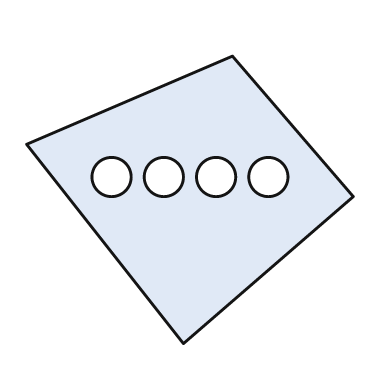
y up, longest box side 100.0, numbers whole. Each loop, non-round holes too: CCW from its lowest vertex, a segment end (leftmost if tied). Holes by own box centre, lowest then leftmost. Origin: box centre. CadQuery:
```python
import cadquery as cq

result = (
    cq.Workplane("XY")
    .moveTo(-2.0, -44.0)
    .lineTo(50.0, 1.0)
    .lineTo(13.0, 44.0)
    .lineTo(-50.0, 17.0)
    .close()
    .moveTo(-24.0, 7.0)
    .circle(6.0)
    .moveTo(-8.0, 7.0)
    .circle(6.0)
    .moveTo(8.0, 7.0)
    .circle(6.0)
    .moveTo(24.0, 7.0)
    .circle(6.0)
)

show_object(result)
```